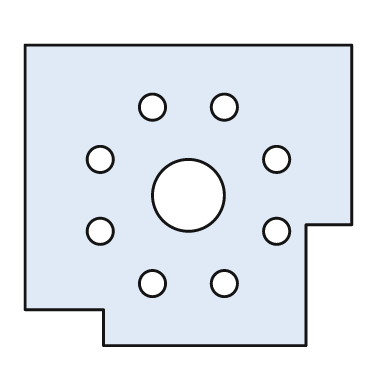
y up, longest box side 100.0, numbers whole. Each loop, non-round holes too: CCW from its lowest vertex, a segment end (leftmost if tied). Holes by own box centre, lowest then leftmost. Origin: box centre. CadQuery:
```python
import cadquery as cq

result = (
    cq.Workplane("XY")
    .moveTo(-26.0, -46.0)
    .lineTo(36.0, -46.0)
    .lineTo(36.0, -9.0)
    .lineTo(50.0, -9.0)
    .lineTo(50.0, 46.0)
    .lineTo(-50.0, 46.0)
    .lineTo(-50.0, -35.0)
    .lineTo(-26.0, -35.0)
    .close()
    .moveTo(-11.0, -27.0)
    .circle(4.0)
    .moveTo(11.0, -27.0)
    .circle(4.0)
    .moveTo(-27.0, -11.0)
    .circle(4.0)
    .moveTo(27.0, -11.0)
    .circle(4.0)
    .moveTo(0.0, 0.0)
    .circle(11.0)
    .moveTo(-27.0, 11.0)
    .circle(4.0)
    .moveTo(27.0, 11.0)
    .circle(4.0)
    .moveTo(-11.0, 27.0)
    .circle(4.0)
    .moveTo(11.0, 27.0)
    .circle(4.0)
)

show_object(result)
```